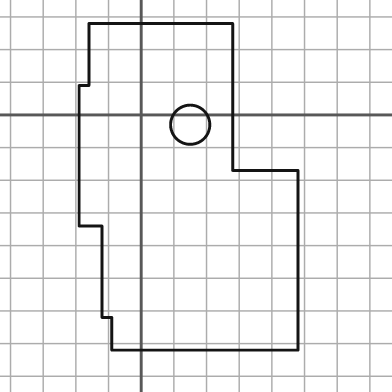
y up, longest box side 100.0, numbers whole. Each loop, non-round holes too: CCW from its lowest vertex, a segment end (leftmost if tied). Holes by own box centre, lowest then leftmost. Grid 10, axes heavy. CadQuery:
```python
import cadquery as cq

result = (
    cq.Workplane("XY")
    .moveTo(-9.0, -72.0)
    .lineTo(48.0, -72.0)
    .lineTo(48.0, -17.0)
    .lineTo(28.0, -17.0)
    .lineTo(28.0, 28.0)
    .lineTo(-16.0, 28.0)
    .lineTo(-16.0, 9.0)
    .lineTo(-19.0, 9.0)
    .lineTo(-19.0, -34.0)
    .lineTo(-12.0, -34.0)
    .lineTo(-12.0, -62.0)
    .lineTo(-9.0, -62.0)
    .close()
    .moveTo(15.0, -3.0)
    .circle(6.0)
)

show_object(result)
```